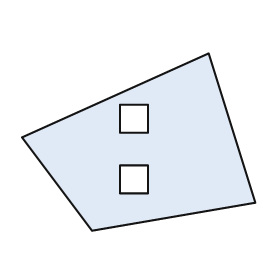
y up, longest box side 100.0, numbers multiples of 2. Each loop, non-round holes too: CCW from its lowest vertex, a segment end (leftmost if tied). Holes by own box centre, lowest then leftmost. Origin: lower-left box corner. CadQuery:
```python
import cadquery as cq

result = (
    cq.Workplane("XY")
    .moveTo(30.0, 0.0)
    .lineTo(100.0, 12.0)
    .lineTo(80.0, 76.0)
    .lineTo(0.0, 40.0)
    .close()
    .moveTo(42.0, 16.0)
    .lineTo(54.0, 16.0)
    .lineTo(54.0, 28.0)
    .lineTo(42.0, 28.0)
    .close()
    .moveTo(42.0, 42.0)
    .lineTo(54.0, 42.0)
    .lineTo(54.0, 54.0)
    .lineTo(42.0, 54.0)
    .close()
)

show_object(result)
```